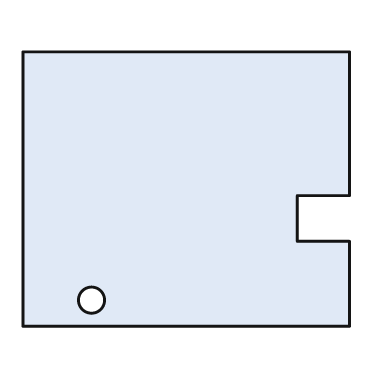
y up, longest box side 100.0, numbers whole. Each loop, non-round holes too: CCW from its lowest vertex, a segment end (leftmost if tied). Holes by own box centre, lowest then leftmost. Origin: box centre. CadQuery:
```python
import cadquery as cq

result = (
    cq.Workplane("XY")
    .moveTo(-50.0, -42.0)
    .lineTo(50.0, -42.0)
    .lineTo(50.0, -16.0)
    .lineTo(34.0, -16.0)
    .lineTo(34.0, -2.0)
    .lineTo(50.0, -2.0)
    .lineTo(50.0, 42.0)
    .lineTo(-50.0, 42.0)
    .close()
    .moveTo(-29.0, -34.0)
    .circle(4.0)
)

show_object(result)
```